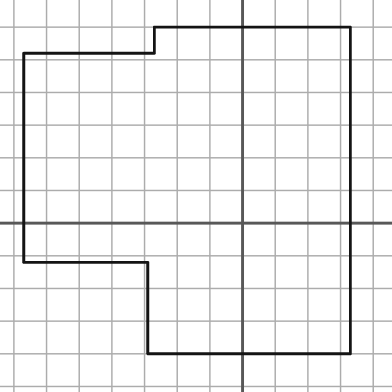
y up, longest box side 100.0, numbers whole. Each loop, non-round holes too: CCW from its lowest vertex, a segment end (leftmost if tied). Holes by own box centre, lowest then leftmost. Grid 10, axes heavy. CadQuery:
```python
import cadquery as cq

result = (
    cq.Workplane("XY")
    .moveTo(-29.0, -40.0)
    .lineTo(33.0, -40.0)
    .lineTo(33.0, 60.0)
    .lineTo(-27.0, 60.0)
    .lineTo(-27.0, 52.0)
    .lineTo(-67.0, 52.0)
    .lineTo(-67.0, -12.0)
    .lineTo(-29.0, -12.0)
    .close()
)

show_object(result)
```